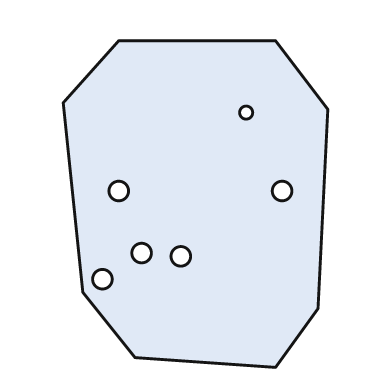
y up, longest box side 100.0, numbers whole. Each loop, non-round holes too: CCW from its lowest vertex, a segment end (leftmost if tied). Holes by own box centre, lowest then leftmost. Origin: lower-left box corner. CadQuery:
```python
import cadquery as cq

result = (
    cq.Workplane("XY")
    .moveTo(65.0, 0.0)
    .lineTo(78.0, 18.0)
    .lineTo(81.0, 79.0)
    .lineTo(65.0, 100.0)
    .lineTo(17.0, 100.0)
    .lineTo(0.0, 81.0)
    .lineTo(6.0, 23.0)
    .lineTo(22.0, 3.0)
    .close()
    .moveTo(12.0, 27.0)
    .circle(3.0)
    .moveTo(36.0, 34.0)
    .circle(3.0)
    .moveTo(24.0, 35.0)
    .circle(3.0)
    .moveTo(17.0, 54.0)
    .circle(3.0)
    .moveTo(67.0, 54.0)
    .circle(3.0)
    .moveTo(56.0, 78.0)
    .circle(2.0)
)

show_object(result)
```